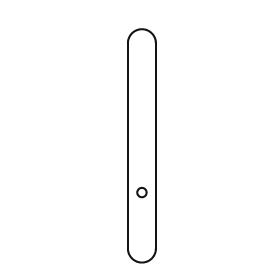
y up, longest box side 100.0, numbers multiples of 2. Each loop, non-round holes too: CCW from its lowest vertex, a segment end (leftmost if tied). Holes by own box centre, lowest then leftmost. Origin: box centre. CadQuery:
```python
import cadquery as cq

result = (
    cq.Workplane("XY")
    .moveTo(-6.0, -44.0)
    .threePointArc((0.0, -50.0), (6.0, -44.0))
    .lineTo(6.0, 44.0)
    .threePointArc((0.0, 50.0), (-6.0, 44.0))
    .close()
    .moveTo(0.0, -20.0)
    .circle(2.0)
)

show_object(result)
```